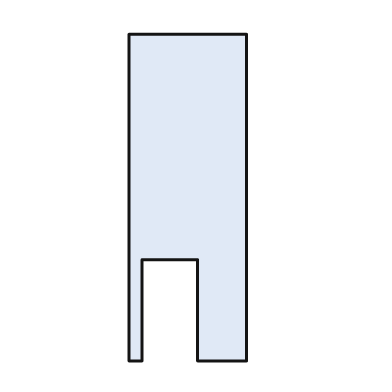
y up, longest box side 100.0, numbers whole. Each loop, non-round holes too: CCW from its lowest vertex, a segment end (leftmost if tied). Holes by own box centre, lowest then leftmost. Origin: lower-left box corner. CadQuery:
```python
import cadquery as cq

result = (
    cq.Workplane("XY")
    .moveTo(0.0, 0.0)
    .lineTo(4.0, 0.0)
    .lineTo(4.0, 31.0)
    .lineTo(21.0, 31.0)
    .lineTo(21.0, 0.0)
    .lineTo(36.0, 0.0)
    .lineTo(36.0, 100.0)
    .lineTo(0.0, 100.0)
    .close()
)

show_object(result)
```